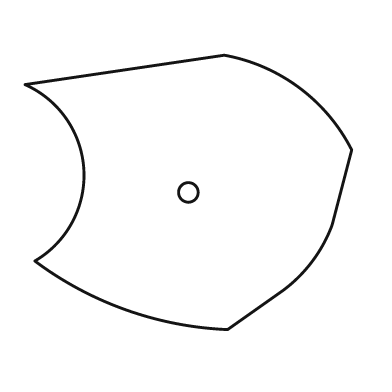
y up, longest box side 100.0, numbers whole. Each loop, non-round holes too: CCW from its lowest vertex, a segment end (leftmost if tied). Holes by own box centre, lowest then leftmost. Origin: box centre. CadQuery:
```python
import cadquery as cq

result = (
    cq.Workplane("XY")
    .moveTo(12.0, -42.0)
    .lineTo(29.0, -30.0)
    .threePointArc((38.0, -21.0), (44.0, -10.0))
    .lineTo(50.0, 13.0)
    .threePointArc((34.0, 32.0), (11.0, 42.0))
    .lineTo(-50.0, 33.0)
    .threePointArc((-32.0, 7.0), (-47.0, -21.0))
    .threePointArc((-19.0, -36.0), (12.0, -42.0))
    .close()
    .moveTo(0.0, 0.0)
    .circle(3.0)
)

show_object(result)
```